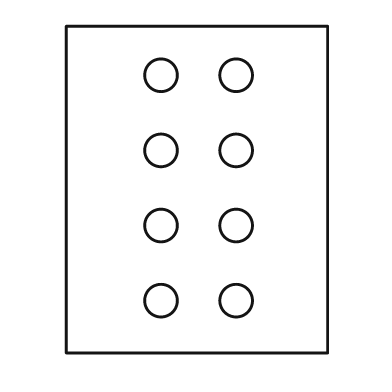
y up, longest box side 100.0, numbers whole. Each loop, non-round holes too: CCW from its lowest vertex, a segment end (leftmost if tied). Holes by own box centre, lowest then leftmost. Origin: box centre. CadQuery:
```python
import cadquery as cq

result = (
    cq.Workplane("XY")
    .moveTo(-40.0, -50.0)
    .lineTo(40.0, -50.0)
    .lineTo(40.0, 50.0)
    .lineTo(-40.0, 50.0)
    .close()
    .moveTo(-11.0, -34.0)
    .circle(5.0)
    .moveTo(12.0, -34.0)
    .circle(5.0)
    .moveTo(-11.0, -11.0)
    .circle(5.0)
    .moveTo(12.0, -11.0)
    .circle(5.0)
    .moveTo(-11.0, 12.0)
    .circle(5.0)
    .moveTo(12.0, 12.0)
    .circle(5.0)
    .moveTo(-11.0, 35.0)
    .circle(5.0)
    .moveTo(12.0, 35.0)
    .circle(5.0)
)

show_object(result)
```